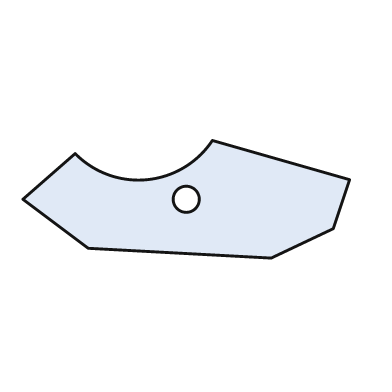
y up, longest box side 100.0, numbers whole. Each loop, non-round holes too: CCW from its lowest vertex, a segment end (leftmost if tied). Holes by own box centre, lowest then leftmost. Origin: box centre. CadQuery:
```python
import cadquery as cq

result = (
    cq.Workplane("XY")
    .moveTo(26.0, -18.0)
    .lineTo(45.0, -9.0)
    .lineTo(50.0, 6.0)
    .lineTo(8.0, 18.0)
    .threePointArc((-12.0, 6.0), (-34.0, 14.0))
    .lineTo(-50.0, 0.0)
    .lineTo(-30.0, -15.0)
    .close()
    .moveTo(0.0, 0.0)
    .circle(4.0)
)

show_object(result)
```